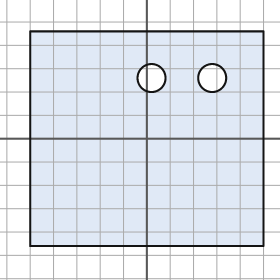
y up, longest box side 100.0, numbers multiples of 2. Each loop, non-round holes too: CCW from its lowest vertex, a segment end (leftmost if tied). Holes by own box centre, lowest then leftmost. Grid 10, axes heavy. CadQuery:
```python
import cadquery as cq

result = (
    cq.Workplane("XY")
    .moveTo(-50.0, -46.0)
    .lineTo(50.0, -46.0)
    .lineTo(50.0, 46.0)
    .lineTo(-50.0, 46.0)
    .close()
    .moveTo(2.0, 26.0)
    .circle(6.0)
    .moveTo(28.0, 26.0)
    .circle(6.0)
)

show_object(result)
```